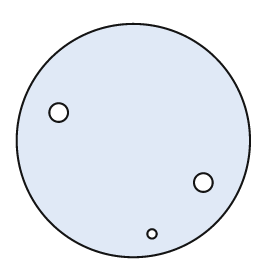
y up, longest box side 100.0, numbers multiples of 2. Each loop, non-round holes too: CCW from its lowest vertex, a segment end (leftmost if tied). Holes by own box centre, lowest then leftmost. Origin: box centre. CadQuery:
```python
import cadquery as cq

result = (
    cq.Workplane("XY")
    .moveTo(0.0, 0.0)
    .circle(50.0)
    .moveTo(8.0, -40.0)
    .circle(2.0)
    .moveTo(30.0, -18.0)
    .circle(4.0)
    .moveTo(-32.0, 12.0)
    .circle(4.0)
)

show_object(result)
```